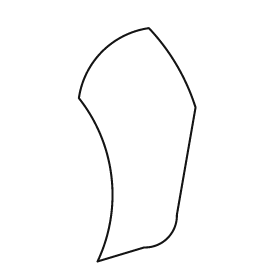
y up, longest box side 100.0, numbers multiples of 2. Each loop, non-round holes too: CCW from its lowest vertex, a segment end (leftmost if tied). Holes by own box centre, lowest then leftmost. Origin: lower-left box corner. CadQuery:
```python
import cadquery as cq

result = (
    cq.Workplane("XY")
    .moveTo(8.0, 0.0)
    .lineTo(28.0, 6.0)
    .threePointArc((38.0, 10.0), (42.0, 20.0))
    .lineTo(50.0, 66.0)
    .threePointArc((42.0, 84.0), (30.0, 100.0))
    .threePointArc((10.0, 90.0), (0.0, 70.0))
    .threePointArc((14.0, 36.0), (8.0, 0.0))
    .close()
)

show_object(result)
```